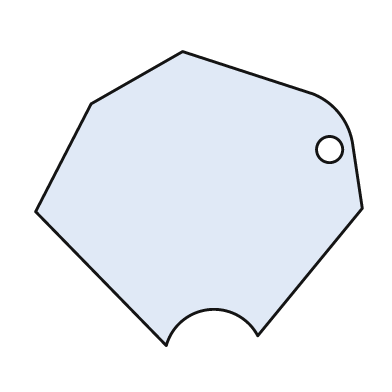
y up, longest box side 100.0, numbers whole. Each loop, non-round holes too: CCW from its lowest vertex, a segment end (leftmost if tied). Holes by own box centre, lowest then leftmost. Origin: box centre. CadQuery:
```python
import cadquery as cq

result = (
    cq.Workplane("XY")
    .moveTo(-10.0, -45.0)
    .threePointArc((3.0, -34.0), (18.0, -42.0))
    .lineTo(50.0, -3.0)
    .lineTo(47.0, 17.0)
    .threePointArc((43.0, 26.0), (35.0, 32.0))
    .lineTo(-5.0, 45.0)
    .lineTo(-33.0, 29.0)
    .lineTo(-50.0, -4.0)
    .close()
    .moveTo(40.0, 15.0)
    .circle(4.0)
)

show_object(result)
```